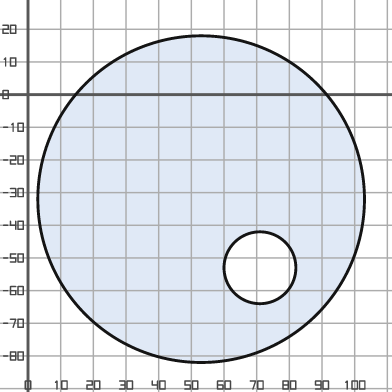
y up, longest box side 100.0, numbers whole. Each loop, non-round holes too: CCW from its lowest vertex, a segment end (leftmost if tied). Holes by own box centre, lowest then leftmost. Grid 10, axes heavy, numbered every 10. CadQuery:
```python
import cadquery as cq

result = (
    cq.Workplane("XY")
    .moveTo(53.0, -32.0)
    .circle(50.0)
    .moveTo(71.0, -53.0)
    .circle(11.0)
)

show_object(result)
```